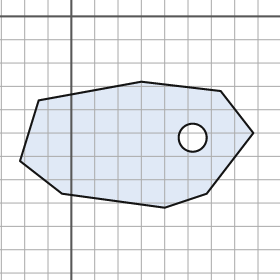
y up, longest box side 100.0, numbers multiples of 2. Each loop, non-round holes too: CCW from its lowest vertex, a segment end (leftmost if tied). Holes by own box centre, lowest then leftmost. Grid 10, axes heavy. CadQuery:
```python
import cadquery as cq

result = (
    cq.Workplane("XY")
    .moveTo(40.0, -82.0)
    .lineTo(58.0, -76.0)
    .lineTo(78.0, -50.0)
    .lineTo(64.0, -32.0)
    .lineTo(30.0, -28.0)
    .lineTo(-14.0, -36.0)
    .lineTo(-22.0, -62.0)
    .lineTo(-4.0, -76.0)
    .close()
    .moveTo(52.0, -52.0)
    .circle(6.0)
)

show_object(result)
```